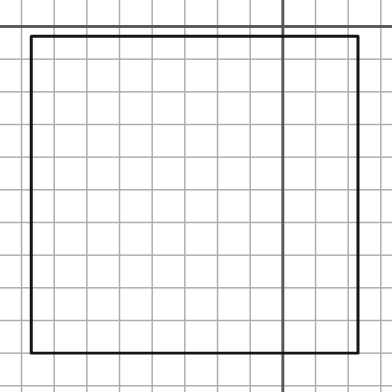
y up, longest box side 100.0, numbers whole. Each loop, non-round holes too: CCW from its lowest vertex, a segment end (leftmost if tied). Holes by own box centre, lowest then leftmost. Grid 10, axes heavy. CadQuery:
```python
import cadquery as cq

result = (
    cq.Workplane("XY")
    .moveTo(-77.0, -100.0)
    .lineTo(23.0, -100.0)
    .lineTo(23.0, -3.0)
    .lineTo(-77.0, -3.0)
    .close()
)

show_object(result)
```